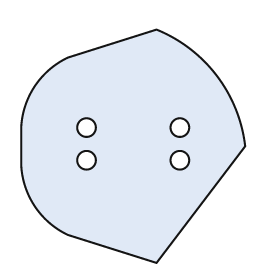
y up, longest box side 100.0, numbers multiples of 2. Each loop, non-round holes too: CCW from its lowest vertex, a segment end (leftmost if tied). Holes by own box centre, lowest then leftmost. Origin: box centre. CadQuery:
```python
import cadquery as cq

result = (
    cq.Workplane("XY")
    .moveTo(10.0, -50.0)
    .lineTo(48.0, 0.0)
    .threePointArc((36.0, 30.0), (10.0, 50.0))
    .lineTo(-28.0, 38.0)
    .threePointArc((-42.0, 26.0), (-48.0, 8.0))
    .lineTo(-48.0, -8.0)
    .threePointArc((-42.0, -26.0), (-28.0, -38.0))
    .close()
    .moveTo(-20.0, -6.0)
    .circle(4.0)
    .moveTo(20.0, -6.0)
    .circle(4.0)
    .moveTo(-20.0, 8.0)
    .circle(4.0)
    .moveTo(20.0, 8.0)
    .circle(4.0)
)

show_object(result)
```